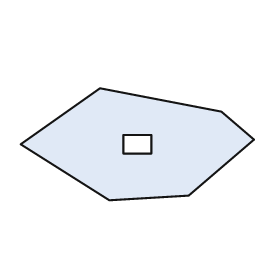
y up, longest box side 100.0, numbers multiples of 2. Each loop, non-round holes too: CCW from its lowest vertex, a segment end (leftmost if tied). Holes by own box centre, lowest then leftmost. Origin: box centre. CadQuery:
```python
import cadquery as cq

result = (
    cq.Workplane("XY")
    .moveTo(-12.0, -24.0)
    .lineTo(22.0, -22.0)
    .lineTo(50.0, 2.0)
    .lineTo(36.0, 14.0)
    .lineTo(-16.0, 24.0)
    .lineTo(-50.0, 0.0)
    .close()
    .moveTo(-6.0, -4.0)
    .lineTo(6.0, -4.0)
    .lineTo(6.0, 4.0)
    .lineTo(-6.0, 4.0)
    .close()
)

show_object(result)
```